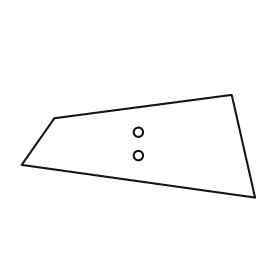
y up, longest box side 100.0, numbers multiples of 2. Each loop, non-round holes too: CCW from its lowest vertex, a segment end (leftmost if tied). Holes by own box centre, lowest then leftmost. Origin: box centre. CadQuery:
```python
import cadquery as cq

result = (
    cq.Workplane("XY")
    .moveTo(50.0, -22.0)
    .lineTo(40.0, 22.0)
    .lineTo(-36.0, 12.0)
    .lineTo(-50.0, -8.0)
    .close()
    .moveTo(0.0, -4.0)
    .circle(2.0)
    .moveTo(0.0, 6.0)
    .circle(2.0)
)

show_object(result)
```